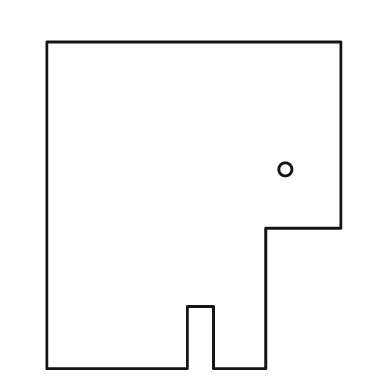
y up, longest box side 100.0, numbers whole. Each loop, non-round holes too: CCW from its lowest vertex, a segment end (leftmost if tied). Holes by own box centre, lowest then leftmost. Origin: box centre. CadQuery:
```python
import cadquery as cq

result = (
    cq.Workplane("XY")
    .moveTo(-45.0, -50.0)
    .lineTo(-2.0, -50.0)
    .lineTo(-2.0, -31.0)
    .lineTo(6.0, -31.0)
    .lineTo(6.0, -50.0)
    .lineTo(22.0, -50.0)
    .lineTo(22.0, -7.0)
    .lineTo(45.0, -7.0)
    .lineTo(45.0, 50.0)
    .lineTo(-45.0, 50.0)
    .close()
    .moveTo(28.0, 11.0)
    .circle(2.0)
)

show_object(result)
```